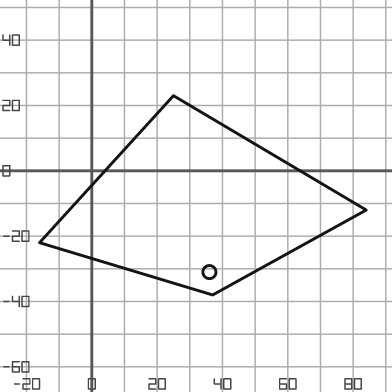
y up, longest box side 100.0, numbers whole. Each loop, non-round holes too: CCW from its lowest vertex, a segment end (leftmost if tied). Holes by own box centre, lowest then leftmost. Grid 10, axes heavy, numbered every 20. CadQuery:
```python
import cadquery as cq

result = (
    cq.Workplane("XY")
    .moveTo(37.0, -38.0)
    .lineTo(84.0, -12.0)
    .lineTo(25.0, 23.0)
    .lineTo(-16.0, -22.0)
    .close()
    .moveTo(36.0, -31.0)
    .circle(2.0)
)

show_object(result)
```